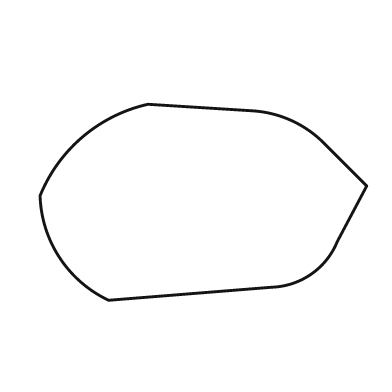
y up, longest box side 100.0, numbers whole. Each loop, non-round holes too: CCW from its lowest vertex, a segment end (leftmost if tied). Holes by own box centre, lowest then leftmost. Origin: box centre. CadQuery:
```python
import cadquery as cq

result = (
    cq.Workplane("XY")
    .moveTo(-29.0, -30.0)
    .lineTo(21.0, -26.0)
    .threePointArc((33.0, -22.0), (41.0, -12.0))
    .lineTo(50.0, 5.0)
    .lineTo(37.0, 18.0)
    .threePointArc((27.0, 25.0), (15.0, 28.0))
    .lineTo(-17.0, 30.0)
    .threePointArc((-37.0, 20.0), (-50.0, 2.0))
    .threePointArc((-44.0, -17.0), (-29.0, -30.0))
    .close()
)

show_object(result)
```